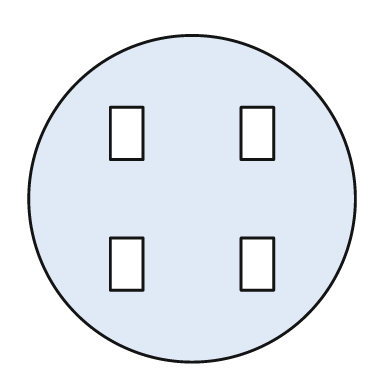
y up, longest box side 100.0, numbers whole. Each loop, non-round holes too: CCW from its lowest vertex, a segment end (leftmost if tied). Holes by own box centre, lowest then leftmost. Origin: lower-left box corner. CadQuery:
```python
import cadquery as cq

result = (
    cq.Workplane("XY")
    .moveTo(50.0, 50.0)
    .circle(50.0)
    .moveTo(25.0, 22.0)
    .lineTo(35.0, 22.0)
    .lineTo(35.0, 38.0)
    .lineTo(25.0, 38.0)
    .close()
    .moveTo(65.0, 22.0)
    .lineTo(75.0, 22.0)
    .lineTo(75.0, 38.0)
    .lineTo(65.0, 38.0)
    .close()
    .moveTo(25.0, 62.0)
    .lineTo(35.0, 62.0)
    .lineTo(35.0, 78.0)
    .lineTo(25.0, 78.0)
    .close()
    .moveTo(65.0, 62.0)
    .lineTo(75.0, 62.0)
    .lineTo(75.0, 78.0)
    .lineTo(65.0, 78.0)
    .close()
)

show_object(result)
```